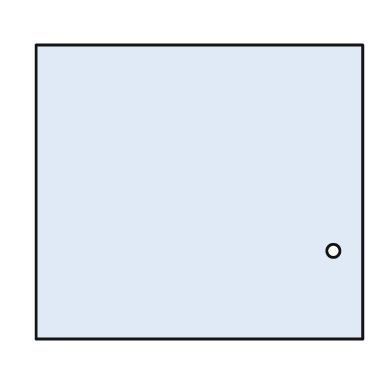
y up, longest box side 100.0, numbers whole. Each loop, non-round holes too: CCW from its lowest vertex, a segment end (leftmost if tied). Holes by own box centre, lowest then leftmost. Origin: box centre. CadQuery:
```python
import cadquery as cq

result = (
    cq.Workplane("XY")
    .moveTo(-50.0, -45.0)
    .lineTo(50.0, -45.0)
    .lineTo(50.0, 45.0)
    .lineTo(-50.0, 45.0)
    .close()
    .moveTo(41.0, -18.0)
    .circle(2.0)
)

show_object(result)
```